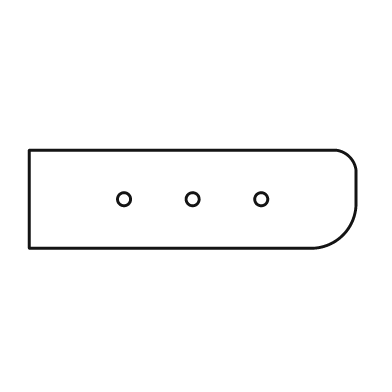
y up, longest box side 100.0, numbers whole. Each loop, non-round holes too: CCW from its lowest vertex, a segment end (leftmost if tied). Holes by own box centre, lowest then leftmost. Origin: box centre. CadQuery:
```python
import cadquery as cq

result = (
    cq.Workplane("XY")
    .moveTo(-50.0, -15.0)
    .lineTo(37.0, -15.0)
    .threePointArc((46.0, -11.0), (50.0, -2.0))
    .lineTo(50.0, 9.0)
    .threePointArc((48.0, 13.0), (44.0, 15.0))
    .lineTo(-50.0, 15.0)
    .close()
    .moveTo(-21.0, 0.0)
    .circle(2.0)
    .moveTo(0.0, 0.0)
    .circle(2.0)
    .moveTo(21.0, 0.0)
    .circle(2.0)
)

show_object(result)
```